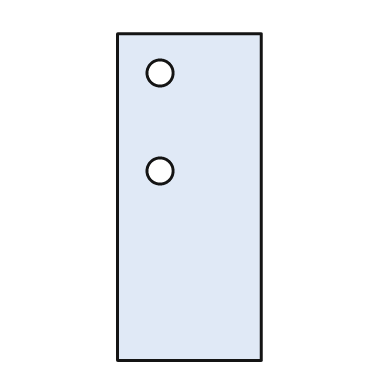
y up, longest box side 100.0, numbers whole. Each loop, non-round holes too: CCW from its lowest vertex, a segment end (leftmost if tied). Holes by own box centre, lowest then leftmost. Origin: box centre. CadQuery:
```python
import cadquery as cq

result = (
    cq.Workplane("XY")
    .moveTo(-22.0, -50.0)
    .lineTo(22.0, -50.0)
    .lineTo(22.0, 50.0)
    .lineTo(-22.0, 50.0)
    .close()
    .moveTo(-9.0, 8.0)
    .circle(4.0)
    .moveTo(-9.0, 38.0)
    .circle(4.0)
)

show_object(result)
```